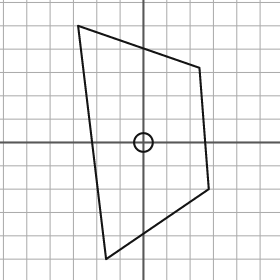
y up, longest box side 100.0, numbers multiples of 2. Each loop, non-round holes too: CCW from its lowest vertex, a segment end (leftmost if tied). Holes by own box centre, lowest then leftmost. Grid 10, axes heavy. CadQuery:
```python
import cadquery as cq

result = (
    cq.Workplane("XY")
    .moveTo(-16.0, -50.0)
    .lineTo(28.0, -20.0)
    .lineTo(24.0, 32.0)
    .lineTo(-28.0, 50.0)
    .close()
    .moveTo(0.0, 0.0)
    .circle(4.0)
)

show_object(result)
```